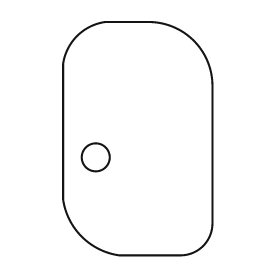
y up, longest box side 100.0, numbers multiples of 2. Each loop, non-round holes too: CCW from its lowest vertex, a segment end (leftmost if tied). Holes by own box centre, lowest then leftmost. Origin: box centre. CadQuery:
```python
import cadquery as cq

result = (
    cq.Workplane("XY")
    .moveTo(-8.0, -50.0)
    .lineTo(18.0, -50.0)
    .threePointArc((28.0, -46.0), (32.0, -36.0))
    .lineTo(32.0, 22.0)
    .threePointArc((24.0, 42.0), (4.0, 50.0))
    .lineTo(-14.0, 50.0)
    .threePointArc((-26.0, 44.0), (-32.0, 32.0))
    .lineTo(-32.0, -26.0)
    .threePointArc((-24.0, -42.0), (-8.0, -50.0))
    .close()
    .moveTo(-18.0, -8.0)
    .circle(6.0)
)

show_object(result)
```